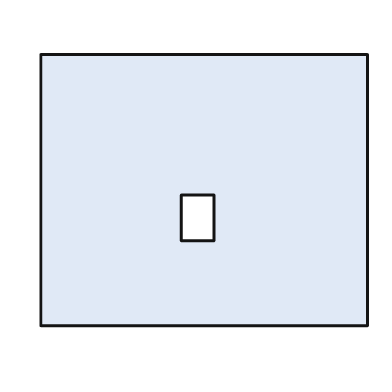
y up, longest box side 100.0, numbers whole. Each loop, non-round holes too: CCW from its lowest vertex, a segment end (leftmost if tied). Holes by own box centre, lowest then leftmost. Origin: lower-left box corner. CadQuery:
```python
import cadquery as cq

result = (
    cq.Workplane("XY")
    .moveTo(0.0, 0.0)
    .lineTo(100.0, 0.0)
    .lineTo(100.0, 83.0)
    .lineTo(0.0, 83.0)
    .close()
    .moveTo(43.0, 26.0)
    .lineTo(53.0, 26.0)
    .lineTo(53.0, 40.0)
    .lineTo(43.0, 40.0)
    .close()
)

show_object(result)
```